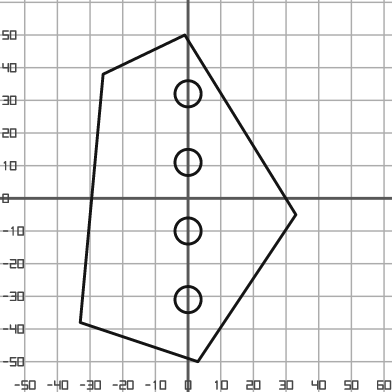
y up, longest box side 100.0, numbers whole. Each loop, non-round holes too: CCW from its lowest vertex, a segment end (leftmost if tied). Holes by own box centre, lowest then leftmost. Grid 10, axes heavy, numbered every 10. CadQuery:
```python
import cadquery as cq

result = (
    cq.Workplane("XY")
    .moveTo(3.0, -50.0)
    .lineTo(33.0, -5.0)
    .lineTo(-1.0, 50.0)
    .lineTo(-26.0, 38.0)
    .lineTo(-33.0, -38.0)
    .close()
    .moveTo(0.0, -31.0)
    .circle(4.0)
    .moveTo(0.0, -10.0)
    .circle(4.0)
    .moveTo(0.0, 11.0)
    .circle(4.0)
    .moveTo(0.0, 32.0)
    .circle(4.0)
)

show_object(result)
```